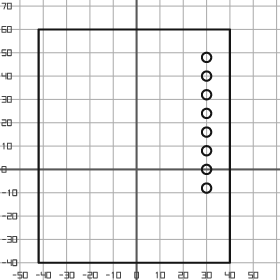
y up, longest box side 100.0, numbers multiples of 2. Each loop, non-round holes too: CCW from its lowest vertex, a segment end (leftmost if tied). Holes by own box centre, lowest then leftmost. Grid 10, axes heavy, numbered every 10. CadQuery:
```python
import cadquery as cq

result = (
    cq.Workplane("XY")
    .moveTo(-42.0, -40.0)
    .lineTo(40.0, -40.0)
    .lineTo(40.0, 60.0)
    .lineTo(-42.0, 60.0)
    .close()
    .moveTo(30.0, -8.0)
    .circle(2.0)
    .moveTo(30.0, 0.0)
    .circle(2.0)
    .moveTo(30.0, 8.0)
    .circle(2.0)
    .moveTo(30.0, 16.0)
    .circle(2.0)
    .moveTo(30.0, 24.0)
    .circle(2.0)
    .moveTo(30.0, 32.0)
    .circle(2.0)
    .moveTo(30.0, 40.0)
    .circle(2.0)
    .moveTo(30.0, 48.0)
    .circle(2.0)
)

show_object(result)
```